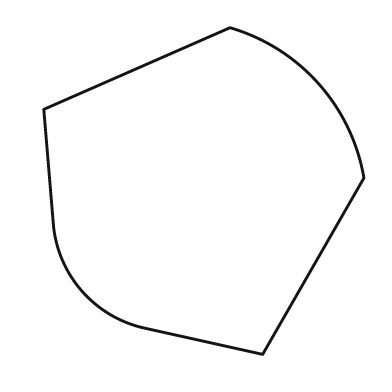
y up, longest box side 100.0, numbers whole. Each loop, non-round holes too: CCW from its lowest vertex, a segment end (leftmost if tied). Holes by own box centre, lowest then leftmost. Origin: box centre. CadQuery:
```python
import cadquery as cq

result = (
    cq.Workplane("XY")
    .moveTo(18.0, -50.0)
    .lineTo(49.0, 4.0)
    .threePointArc((35.0, 33.0), (8.0, 50.0))
    .lineTo(-49.0, 25.0)
    .lineTo(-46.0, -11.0)
    .threePointArc((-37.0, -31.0), (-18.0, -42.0))
    .close()
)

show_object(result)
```